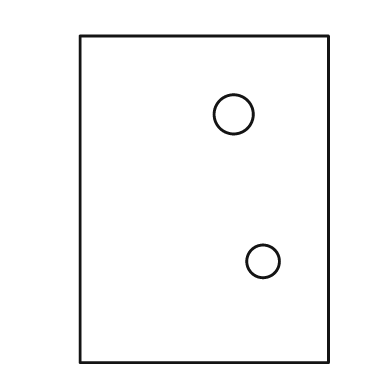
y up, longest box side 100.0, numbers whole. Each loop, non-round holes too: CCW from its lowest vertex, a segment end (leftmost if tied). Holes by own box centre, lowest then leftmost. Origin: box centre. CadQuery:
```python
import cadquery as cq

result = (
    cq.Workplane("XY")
    .moveTo(-38.0, -50.0)
    .lineTo(38.0, -50.0)
    .lineTo(38.0, 50.0)
    .lineTo(-38.0, 50.0)
    .close()
    .moveTo(18.0, -19.0)
    .circle(5.0)
    .moveTo(9.0, 26.0)
    .circle(6.0)
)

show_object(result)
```